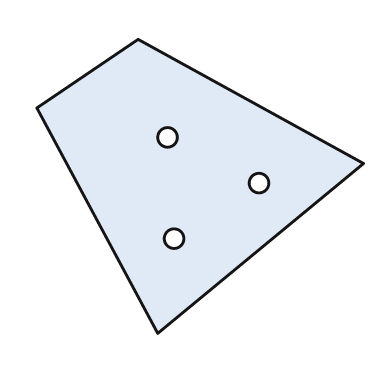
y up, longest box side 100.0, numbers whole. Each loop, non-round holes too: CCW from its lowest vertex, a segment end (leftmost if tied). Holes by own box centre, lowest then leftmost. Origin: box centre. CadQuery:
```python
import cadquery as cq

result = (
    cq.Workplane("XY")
    .moveTo(-13.0, -45.0)
    .lineTo(50.0, 7.0)
    .lineTo(-19.0, 45.0)
    .lineTo(-50.0, 24.0)
    .close()
    .moveTo(-8.0, -16.0)
    .circle(3.0)
    .moveTo(18.0, 1.0)
    .circle(3.0)
    .moveTo(-10.0, 15.0)
    .circle(3.0)
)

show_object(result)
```